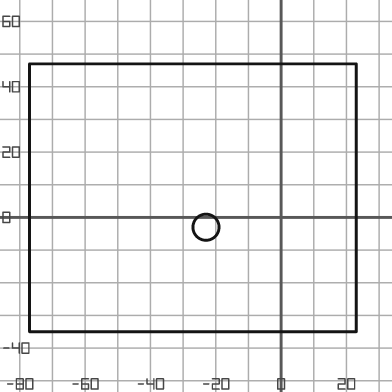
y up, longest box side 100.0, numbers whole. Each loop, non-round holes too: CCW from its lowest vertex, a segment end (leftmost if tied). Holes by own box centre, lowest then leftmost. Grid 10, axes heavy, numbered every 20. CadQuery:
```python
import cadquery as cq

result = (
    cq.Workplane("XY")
    .moveTo(-77.0, -35.0)
    .lineTo(23.0, -35.0)
    .lineTo(23.0, 47.0)
    .lineTo(-77.0, 47.0)
    .close()
    .moveTo(-23.0, -3.0)
    .circle(4.0)
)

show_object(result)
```